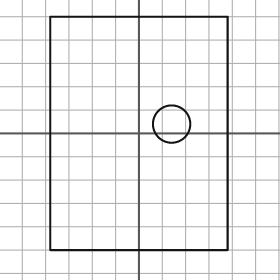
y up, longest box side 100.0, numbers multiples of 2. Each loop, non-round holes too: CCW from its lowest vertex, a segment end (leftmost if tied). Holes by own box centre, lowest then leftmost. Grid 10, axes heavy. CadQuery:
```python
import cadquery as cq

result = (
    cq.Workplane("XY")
    .moveTo(-38.0, -50.0)
    .lineTo(38.0, -50.0)
    .lineTo(38.0, 50.0)
    .lineTo(-38.0, 50.0)
    .close()
    .moveTo(14.0, 4.0)
    .circle(8.0)
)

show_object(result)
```